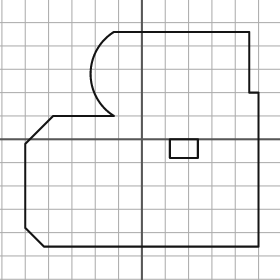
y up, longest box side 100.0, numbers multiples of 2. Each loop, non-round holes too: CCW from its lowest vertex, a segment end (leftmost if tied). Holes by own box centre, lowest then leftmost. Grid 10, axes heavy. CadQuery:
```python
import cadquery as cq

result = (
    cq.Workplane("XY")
    .moveTo(-42.0, -46.0)
    .lineTo(50.0, -46.0)
    .lineTo(50.0, 20.0)
    .lineTo(46.0, 20.0)
    .lineTo(46.0, 46.0)
    .lineTo(-12.0, 46.0)
    .threePointArc((-22.0, 28.0), (-12.0, 10.0))
    .lineTo(-38.0, 10.0)
    .lineTo(-50.0, -2.0)
    .lineTo(-50.0, -38.0)
    .close()
    .moveTo(12.0, -8.0)
    .lineTo(24.0, -8.0)
    .lineTo(24.0, 0.0)
    .lineTo(12.0, 0.0)
    .close()
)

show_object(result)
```